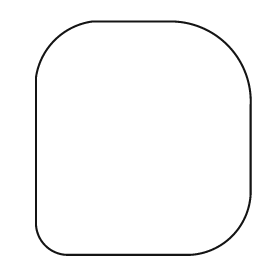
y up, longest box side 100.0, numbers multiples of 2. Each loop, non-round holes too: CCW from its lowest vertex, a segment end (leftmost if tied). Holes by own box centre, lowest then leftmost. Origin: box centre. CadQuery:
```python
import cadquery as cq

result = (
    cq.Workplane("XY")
    .moveTo(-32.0, -50.0)
    .lineTo(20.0, -50.0)
    .threePointArc((38.0, -42.0), (46.0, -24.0))
    .lineTo(46.0, 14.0)
    .threePointArc((36.0, 40.0), (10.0, 50.0))
    .lineTo(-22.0, 50.0)
    .threePointArc((-38.0, 42.0), (-46.0, 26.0))
    .lineTo(-46.0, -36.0)
    .threePointArc((-42.0, -46.0), (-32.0, -50.0))
    .close()
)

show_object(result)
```